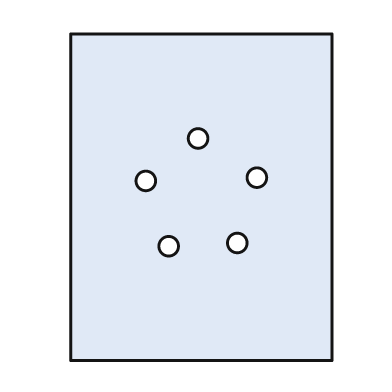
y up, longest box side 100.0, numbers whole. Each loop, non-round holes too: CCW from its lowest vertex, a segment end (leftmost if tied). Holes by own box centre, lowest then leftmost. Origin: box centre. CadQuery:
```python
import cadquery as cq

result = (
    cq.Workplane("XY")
    .moveTo(-40.0, -50.0)
    .lineTo(40.0, -50.0)
    .lineTo(40.0, 50.0)
    .lineTo(-40.0, 50.0)
    .close()
    .moveTo(-10.0, -15.0)
    .circle(3.0)
    .moveTo(11.0, -14.0)
    .circle(3.0)
    .moveTo(-17.0, 5.0)
    .circle(3.0)
    .moveTo(17.0, 6.0)
    .circle(3.0)
    .moveTo(-1.0, 18.0)
    .circle(3.0)
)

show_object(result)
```